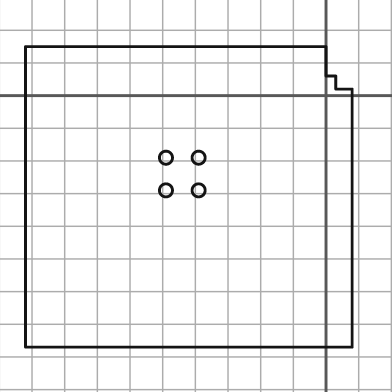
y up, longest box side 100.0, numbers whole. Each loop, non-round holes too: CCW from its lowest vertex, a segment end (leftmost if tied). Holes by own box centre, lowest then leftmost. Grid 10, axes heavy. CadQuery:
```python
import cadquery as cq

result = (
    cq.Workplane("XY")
    .moveTo(-92.0, -77.0)
    .lineTo(8.0, -77.0)
    .lineTo(8.0, 2.0)
    .lineTo(3.0, 2.0)
    .lineTo(3.0, 6.0)
    .lineTo(0.0, 6.0)
    .lineTo(0.0, 15.0)
    .lineTo(-92.0, 15.0)
    .close()
    .moveTo(-49.0, -29.0)
    .circle(2.0)
    .moveTo(-39.0, -29.0)
    .circle(2.0)
    .moveTo(-49.0, -19.0)
    .circle(2.0)
    .moveTo(-39.0, -19.0)
    .circle(2.0)
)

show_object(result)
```